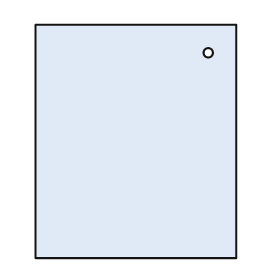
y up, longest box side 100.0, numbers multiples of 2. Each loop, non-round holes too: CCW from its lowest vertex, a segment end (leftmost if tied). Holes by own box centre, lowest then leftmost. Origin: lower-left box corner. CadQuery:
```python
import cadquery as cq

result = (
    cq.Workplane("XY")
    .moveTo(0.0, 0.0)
    .lineTo(86.0, 0.0)
    .lineTo(86.0, 100.0)
    .lineTo(0.0, 100.0)
    .close()
    .moveTo(74.0, 88.0)
    .circle(2.0)
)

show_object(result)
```